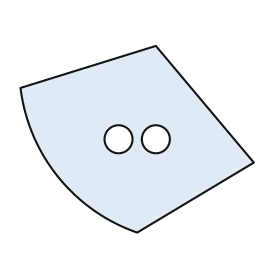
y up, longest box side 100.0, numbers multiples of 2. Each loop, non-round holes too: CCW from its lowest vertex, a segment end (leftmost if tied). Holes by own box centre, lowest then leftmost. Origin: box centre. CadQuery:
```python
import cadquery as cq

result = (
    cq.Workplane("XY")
    .moveTo(0.0, -40.0)
    .lineTo(50.0, -10.0)
    .lineTo(8.0, 40.0)
    .lineTo(-50.0, 22.0)
    .threePointArc((-34.0, -16.0), (0.0, -40.0))
    .close()
    .moveTo(-8.0, 0.0)
    .circle(6.0)
    .moveTo(8.0, 0.0)
    .circle(6.0)
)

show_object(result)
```